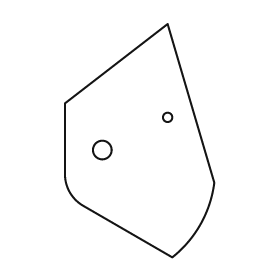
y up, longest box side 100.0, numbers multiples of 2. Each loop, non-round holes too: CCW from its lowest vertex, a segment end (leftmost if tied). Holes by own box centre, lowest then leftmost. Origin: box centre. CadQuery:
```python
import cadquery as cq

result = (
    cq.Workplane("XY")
    .moveTo(14.0, -50.0)
    .threePointArc((26.0, -36.0), (32.0, -18.0))
    .lineTo(12.0, 50.0)
    .lineTo(-32.0, 16.0)
    .lineTo(-32.0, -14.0)
    .threePointArc((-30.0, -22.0), (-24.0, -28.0))
    .close()
    .moveTo(-16.0, -4.0)
    .circle(4.0)
    .moveTo(12.0, 10.0)
    .circle(2.0)
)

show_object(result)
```